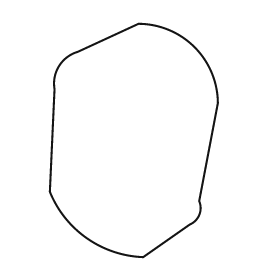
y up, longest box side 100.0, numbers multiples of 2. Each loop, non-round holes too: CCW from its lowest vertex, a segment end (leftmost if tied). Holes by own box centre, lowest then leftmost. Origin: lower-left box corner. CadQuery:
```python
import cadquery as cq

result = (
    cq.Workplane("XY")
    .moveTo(40.0, 0.0)
    .lineTo(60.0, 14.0)
    .threePointArc((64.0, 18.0), (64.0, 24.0))
    .lineTo(72.0, 66.0)
    .threePointArc((62.0, 90.0), (38.0, 100.0))
    .lineTo(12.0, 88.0)
    .threePointArc((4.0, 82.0), (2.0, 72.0))
    .lineTo(0.0, 28.0)
    .threePointArc((16.0, 8.0), (40.0, 0.0))
    .close()
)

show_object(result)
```